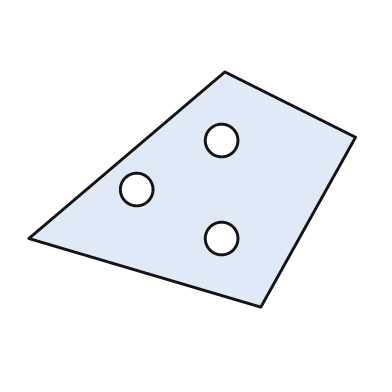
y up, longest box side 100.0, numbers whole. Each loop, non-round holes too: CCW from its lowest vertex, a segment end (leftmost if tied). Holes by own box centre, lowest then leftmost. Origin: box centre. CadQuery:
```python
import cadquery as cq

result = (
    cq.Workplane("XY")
    .moveTo(21.0, -36.0)
    .lineTo(50.0, 16.0)
    .lineTo(10.0, 36.0)
    .lineTo(-50.0, -15.0)
    .close()
    .moveTo(9.0, -15.0)
    .circle(5.0)
    .moveTo(-17.0, 0.0)
    .circle(5.0)
    .moveTo(9.0, 15.0)
    .circle(5.0)
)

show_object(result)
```